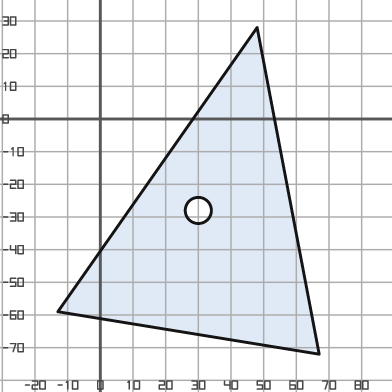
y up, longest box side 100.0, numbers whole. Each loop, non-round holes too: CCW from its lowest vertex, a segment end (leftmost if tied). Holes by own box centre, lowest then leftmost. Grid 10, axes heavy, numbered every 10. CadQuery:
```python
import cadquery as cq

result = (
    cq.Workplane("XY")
    .moveTo(67.0, -72.0)
    .lineTo(48.0, 28.0)
    .lineTo(-13.0, -59.0)
    .close()
    .moveTo(30.0, -28.0)
    .circle(4.0)
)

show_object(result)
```